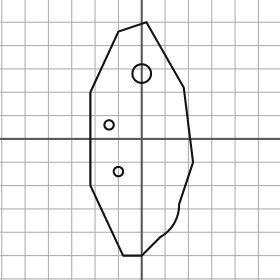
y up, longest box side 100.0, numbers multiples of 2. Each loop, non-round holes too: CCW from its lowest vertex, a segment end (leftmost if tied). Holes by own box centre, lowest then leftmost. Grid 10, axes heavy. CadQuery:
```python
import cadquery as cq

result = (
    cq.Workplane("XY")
    .moveTo(-8.0, -50.0)
    .lineTo(0.0, -50.0)
    .lineTo(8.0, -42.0)
    .threePointArc((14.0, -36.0), (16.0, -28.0))
    .lineTo(22.0, -10.0)
    .lineTo(18.0, 22.0)
    .lineTo(2.0, 50.0)
    .lineTo(-10.0, 46.0)
    .lineTo(-22.0, 20.0)
    .lineTo(-22.0, -20.0)
    .close()
    .moveTo(-10.0, -14.0)
    .circle(2.0)
    .moveTo(-14.0, 6.0)
    .circle(2.0)
    .moveTo(0.0, 28.0)
    .circle(4.0)
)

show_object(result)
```